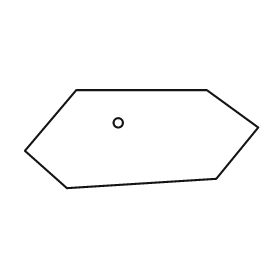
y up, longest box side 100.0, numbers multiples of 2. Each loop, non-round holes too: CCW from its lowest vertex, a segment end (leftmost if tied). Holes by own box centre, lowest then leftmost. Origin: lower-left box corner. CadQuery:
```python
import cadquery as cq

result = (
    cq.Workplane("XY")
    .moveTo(18.0, 0.0)
    .lineTo(82.0, 4.0)
    .lineTo(100.0, 26.0)
    .lineTo(78.0, 42.0)
    .lineTo(22.0, 42.0)
    .lineTo(0.0, 16.0)
    .close()
    .moveTo(40.0, 28.0)
    .circle(2.0)
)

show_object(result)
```